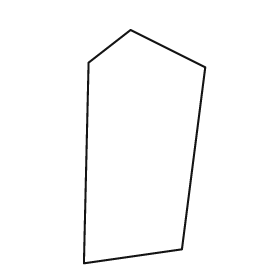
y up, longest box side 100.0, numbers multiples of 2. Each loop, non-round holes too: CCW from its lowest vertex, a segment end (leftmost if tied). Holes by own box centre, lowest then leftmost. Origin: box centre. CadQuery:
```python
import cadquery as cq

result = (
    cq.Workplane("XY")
    .moveTo(-26.0, -50.0)
    .lineTo(16.0, -44.0)
    .lineTo(26.0, 34.0)
    .lineTo(-6.0, 50.0)
    .lineTo(-24.0, 36.0)
    .close()
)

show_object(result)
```